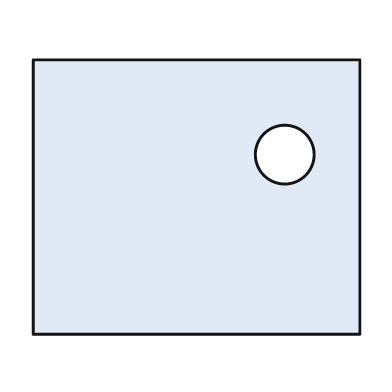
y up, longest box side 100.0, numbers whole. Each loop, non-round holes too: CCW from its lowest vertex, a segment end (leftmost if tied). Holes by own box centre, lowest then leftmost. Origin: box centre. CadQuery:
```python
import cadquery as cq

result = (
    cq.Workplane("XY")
    .moveTo(-50.0, -42.0)
    .lineTo(50.0, -42.0)
    .lineTo(50.0, 42.0)
    .lineTo(-50.0, 42.0)
    .close()
    .moveTo(27.0, 13.0)
    .circle(9.0)
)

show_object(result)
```